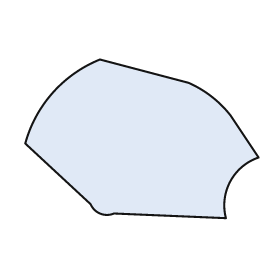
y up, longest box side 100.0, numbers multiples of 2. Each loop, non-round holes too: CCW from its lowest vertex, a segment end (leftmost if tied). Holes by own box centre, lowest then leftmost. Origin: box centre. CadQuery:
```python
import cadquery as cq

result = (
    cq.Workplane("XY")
    .moveTo(36.0, -34.0)
    .threePointArc((38.0, -18.0), (50.0, -8.0))
    .lineTo(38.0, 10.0)
    .threePointArc((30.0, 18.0), (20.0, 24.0))
    .lineTo(-18.0, 34.0)
    .threePointArc((-38.0, 20.0), (-50.0, -2.0))
    .lineTo(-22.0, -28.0)
    .threePointArc((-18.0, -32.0), (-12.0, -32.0))
    .close()
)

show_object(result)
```